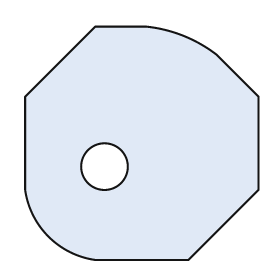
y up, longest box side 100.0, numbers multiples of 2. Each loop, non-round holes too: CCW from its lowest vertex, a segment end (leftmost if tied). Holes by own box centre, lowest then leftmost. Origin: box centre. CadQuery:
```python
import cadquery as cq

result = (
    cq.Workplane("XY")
    .moveTo(-20.0, -50.0)
    .lineTo(20.0, -50.0)
    .lineTo(50.0, -20.0)
    .lineTo(50.0, 20.0)
    .lineTo(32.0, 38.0)
    .threePointArc((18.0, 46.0), (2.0, 50.0))
    .lineTo(-20.0, 50.0)
    .lineTo(-50.0, 20.0)
    .lineTo(-50.0, -20.0)
    .threePointArc((-40.0, -40.0), (-20.0, -50.0))
    .close()
    .moveTo(-16.0, -10.0)
    .circle(10.0)
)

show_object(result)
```